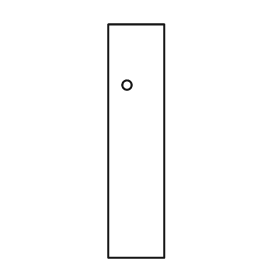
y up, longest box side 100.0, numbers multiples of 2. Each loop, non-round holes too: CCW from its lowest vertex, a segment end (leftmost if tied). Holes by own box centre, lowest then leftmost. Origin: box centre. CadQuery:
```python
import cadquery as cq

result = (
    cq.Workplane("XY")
    .moveTo(-12.0, -50.0)
    .lineTo(12.0, -50.0)
    .lineTo(12.0, 50.0)
    .lineTo(-12.0, 50.0)
    .close()
    .moveTo(-4.0, 24.0)
    .circle(2.0)
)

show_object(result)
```